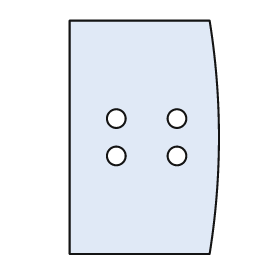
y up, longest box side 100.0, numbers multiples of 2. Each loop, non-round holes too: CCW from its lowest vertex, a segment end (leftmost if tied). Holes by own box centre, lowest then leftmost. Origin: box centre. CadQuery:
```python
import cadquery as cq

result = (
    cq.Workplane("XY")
    .moveTo(-32.0, -50.0)
    .lineTo(28.0, -50.0)
    .threePointArc((32.0, 0.0), (28.0, 50.0))
    .lineTo(-32.0, 50.0)
    .close()
    .moveTo(-12.0, -8.0)
    .circle(4.0)
    .moveTo(14.0, -8.0)
    .circle(4.0)
    .moveTo(-12.0, 8.0)
    .circle(4.0)
    .moveTo(14.0, 8.0)
    .circle(4.0)
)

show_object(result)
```